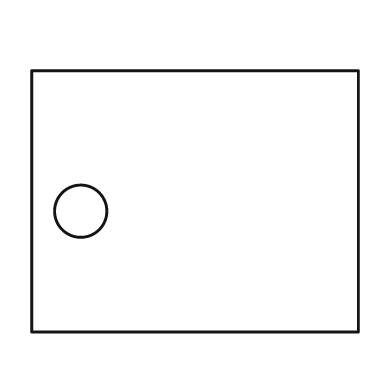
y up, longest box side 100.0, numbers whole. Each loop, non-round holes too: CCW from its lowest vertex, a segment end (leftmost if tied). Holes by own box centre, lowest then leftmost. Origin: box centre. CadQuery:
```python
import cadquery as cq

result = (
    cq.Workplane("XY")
    .moveTo(-50.0, -40.0)
    .lineTo(50.0, -40.0)
    .lineTo(50.0, 40.0)
    .lineTo(-50.0, 40.0)
    .close()
    .moveTo(-35.0, -3.0)
    .circle(8.0)
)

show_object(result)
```